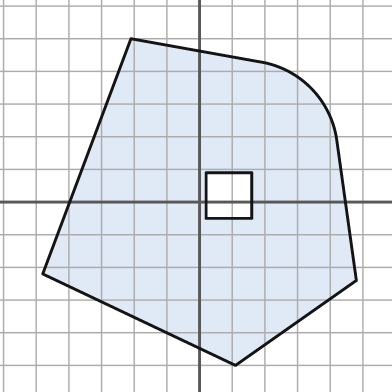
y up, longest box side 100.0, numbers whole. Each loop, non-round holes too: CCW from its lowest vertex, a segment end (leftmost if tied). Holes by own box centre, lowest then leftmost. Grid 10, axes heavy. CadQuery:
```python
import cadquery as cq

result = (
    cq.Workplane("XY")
    .moveTo(11.0, -50.0)
    .lineTo(48.0, -24.0)
    .lineTo(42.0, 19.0)
    .threePointArc((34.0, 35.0), (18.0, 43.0))
    .lineTo(-21.0, 50.0)
    .lineTo(-48.0, -22.0)
    .close()
    .moveTo(2.0, -5.0)
    .lineTo(16.0, -5.0)
    .lineTo(16.0, 9.0)
    .lineTo(2.0, 9.0)
    .close()
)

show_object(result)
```